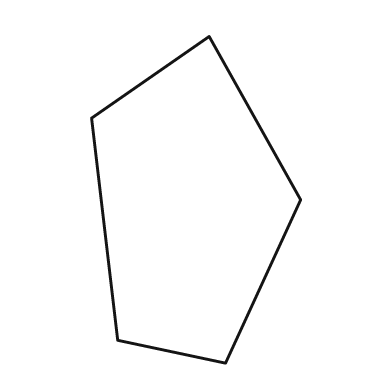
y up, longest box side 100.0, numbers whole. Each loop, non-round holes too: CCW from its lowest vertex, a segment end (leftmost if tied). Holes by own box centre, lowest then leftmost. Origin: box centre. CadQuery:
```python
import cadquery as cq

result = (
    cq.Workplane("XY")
    .moveTo(9.0, -50.0)
    .lineTo(32.0, 0.0)
    .lineTo(4.0, 50.0)
    .lineTo(-32.0, 25.0)
    .lineTo(-24.0, -43.0)
    .close()
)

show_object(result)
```